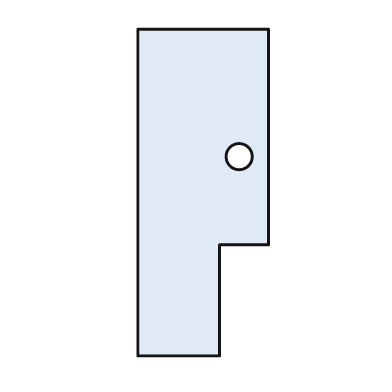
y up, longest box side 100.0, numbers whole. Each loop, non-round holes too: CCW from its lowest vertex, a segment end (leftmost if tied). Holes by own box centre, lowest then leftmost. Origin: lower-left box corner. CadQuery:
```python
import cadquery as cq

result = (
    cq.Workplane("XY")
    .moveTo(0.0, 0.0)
    .lineTo(25.0, 0.0)
    .lineTo(25.0, 34.0)
    .lineTo(40.0, 34.0)
    .lineTo(40.0, 100.0)
    .lineTo(0.0, 100.0)
    .close()
    .moveTo(31.0, 61.0)
    .circle(4.0)
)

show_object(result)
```